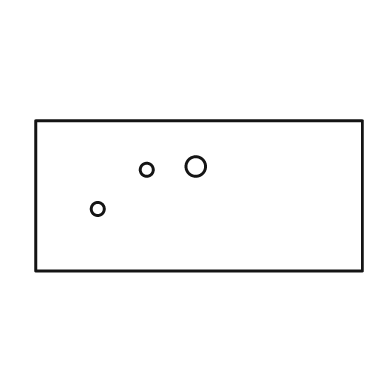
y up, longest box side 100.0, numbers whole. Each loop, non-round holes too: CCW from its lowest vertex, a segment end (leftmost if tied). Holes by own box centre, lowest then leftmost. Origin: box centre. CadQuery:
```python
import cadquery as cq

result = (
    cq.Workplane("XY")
    .moveTo(-50.0, -23.0)
    .lineTo(50.0, -23.0)
    .lineTo(50.0, 23.0)
    .lineTo(-50.0, 23.0)
    .close()
    .moveTo(-31.0, -4.0)
    .circle(2.0)
    .moveTo(-16.0, 8.0)
    .circle(2.0)
    .moveTo(-1.0, 9.0)
    .circle(3.0)
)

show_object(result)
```